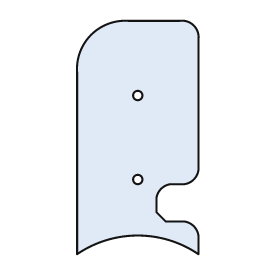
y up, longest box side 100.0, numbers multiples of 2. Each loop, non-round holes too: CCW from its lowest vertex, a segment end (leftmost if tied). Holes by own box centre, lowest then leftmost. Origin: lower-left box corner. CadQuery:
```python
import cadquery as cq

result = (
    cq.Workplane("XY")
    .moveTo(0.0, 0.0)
    .threePointArc((26.0, 8.0), (52.0, 0.0))
    .lineTo(52.0, 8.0)
    .threePointArc((50.0, 12.0), (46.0, 14.0))
    .lineTo(38.0, 14.0)
    .lineTo(34.0, 18.0)
    .lineTo(34.0, 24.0)
    .threePointArc((36.0, 28.0), (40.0, 30.0))
    .lineTo(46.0, 30.0)
    .threePointArc((50.0, 32.0), (52.0, 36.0))
    .lineTo(52.0, 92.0)
    .threePointArc((50.0, 98.0), (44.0, 100.0))
    .lineTo(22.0, 100.0)
    .threePointArc((6.0, 94.0), (0.0, 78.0))
    .close()
    .moveTo(26.0, 32.0)
    .circle(2.0)
    .moveTo(26.0, 68.0)
    .circle(2.0)
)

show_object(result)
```